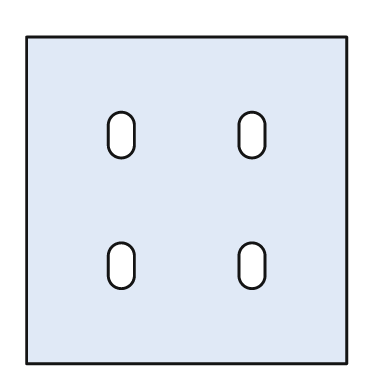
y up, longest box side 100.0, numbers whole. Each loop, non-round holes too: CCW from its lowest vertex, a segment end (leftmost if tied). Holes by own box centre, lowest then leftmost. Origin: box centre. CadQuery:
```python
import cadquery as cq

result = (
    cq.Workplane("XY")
    .moveTo(-49.0, -50.0)
    .lineTo(49.0, -50.0)
    .lineTo(49.0, 50.0)
    .lineTo(-49.0, 50.0)
    .close()
    .moveTo(-24.0, -23.0)
    .threePointArc((-20.0, -27.0), (-16.0, -23.0))
    .lineTo(-16.0, -17.0)
    .threePointArc((-20.0, -13.0), (-24.0, -17.0))
    .close()
    .moveTo(16.0, -23.0)
    .threePointArc((20.0, -27.0), (24.0, -23.0))
    .lineTo(24.0, -17.0)
    .threePointArc((20.0, -13.0), (16.0, -17.0))
    .close()
    .moveTo(-24.0, 17.0)
    .threePointArc((-20.0, 13.0), (-16.0, 17.0))
    .lineTo(-16.0, 23.0)
    .threePointArc((-20.0, 27.0), (-24.0, 23.0))
    .close()
    .moveTo(16.0, 17.0)
    .threePointArc((20.0, 13.0), (24.0, 17.0))
    .lineTo(24.0, 23.0)
    .threePointArc((20.0, 27.0), (16.0, 23.0))
    .close()
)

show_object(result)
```